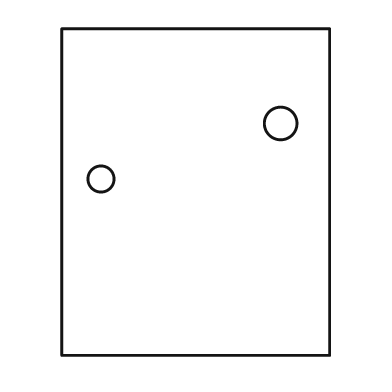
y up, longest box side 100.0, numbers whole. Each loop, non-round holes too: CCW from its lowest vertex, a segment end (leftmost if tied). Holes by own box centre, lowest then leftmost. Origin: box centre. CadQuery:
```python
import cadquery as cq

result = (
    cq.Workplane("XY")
    .moveTo(-41.0, -50.0)
    .lineTo(41.0, -50.0)
    .lineTo(41.0, 50.0)
    .lineTo(-41.0, 50.0)
    .close()
    .moveTo(-29.0, 4.0)
    .circle(4.0)
    .moveTo(26.0, 21.0)
    .circle(5.0)
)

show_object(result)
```